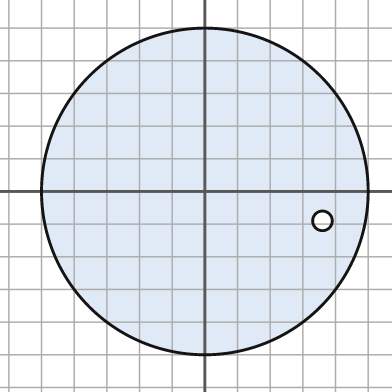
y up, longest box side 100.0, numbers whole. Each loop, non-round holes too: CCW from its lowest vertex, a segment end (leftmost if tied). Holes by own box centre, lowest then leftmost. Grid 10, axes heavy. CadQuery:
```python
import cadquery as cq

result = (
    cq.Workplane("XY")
    .moveTo(0.0, 0.0)
    .circle(50.0)
    .moveTo(36.0, -9.0)
    .circle(3.0)
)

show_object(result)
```